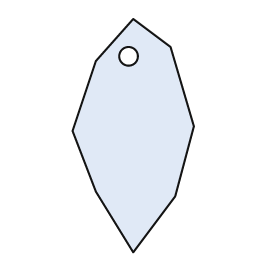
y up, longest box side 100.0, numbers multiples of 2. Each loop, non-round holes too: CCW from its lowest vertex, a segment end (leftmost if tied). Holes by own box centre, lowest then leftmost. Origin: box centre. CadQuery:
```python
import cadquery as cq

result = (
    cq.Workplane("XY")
    .moveTo(0.0, -50.0)
    .lineTo(18.0, -26.0)
    .lineTo(26.0, 4.0)
    .lineTo(16.0, 38.0)
    .lineTo(0.0, 50.0)
    .lineTo(-16.0, 32.0)
    .lineTo(-26.0, 2.0)
    .lineTo(-16.0, -24.0)
    .close()
    .moveTo(-2.0, 34.0)
    .circle(4.0)
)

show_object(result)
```